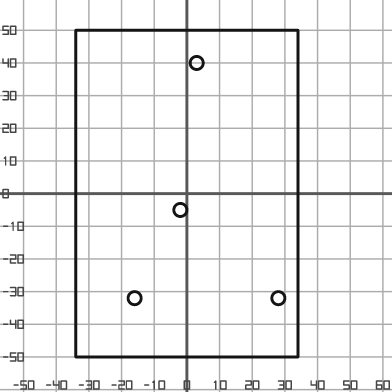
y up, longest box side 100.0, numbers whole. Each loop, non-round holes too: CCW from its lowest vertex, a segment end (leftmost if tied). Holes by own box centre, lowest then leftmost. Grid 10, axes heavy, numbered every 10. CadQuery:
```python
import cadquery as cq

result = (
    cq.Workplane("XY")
    .moveTo(-34.0, -50.0)
    .lineTo(34.0, -50.0)
    .lineTo(34.0, 50.0)
    .lineTo(-34.0, 50.0)
    .close()
    .moveTo(-16.0, -32.0)
    .circle(2.0)
    .moveTo(28.0, -32.0)
    .circle(2.0)
    .moveTo(-2.0, -5.0)
    .circle(2.0)
    .moveTo(3.0, 40.0)
    .circle(2.0)
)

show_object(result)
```